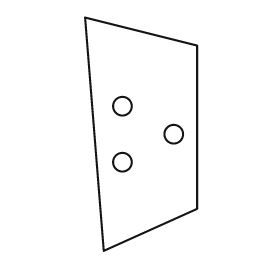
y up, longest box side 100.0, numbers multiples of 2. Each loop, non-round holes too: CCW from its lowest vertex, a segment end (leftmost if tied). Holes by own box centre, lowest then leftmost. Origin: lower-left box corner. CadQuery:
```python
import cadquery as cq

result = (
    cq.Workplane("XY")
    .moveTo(8.0, 0.0)
    .lineTo(48.0, 18.0)
    .lineTo(48.0, 88.0)
    .lineTo(0.0, 100.0)
    .close()
    .moveTo(16.0, 38.0)
    .circle(4.0)
    .moveTo(38.0, 50.0)
    .circle(4.0)
    .moveTo(16.0, 62.0)
    .circle(4.0)
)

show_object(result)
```